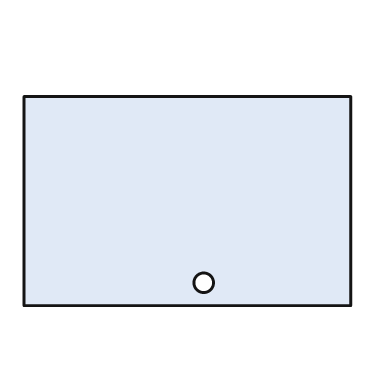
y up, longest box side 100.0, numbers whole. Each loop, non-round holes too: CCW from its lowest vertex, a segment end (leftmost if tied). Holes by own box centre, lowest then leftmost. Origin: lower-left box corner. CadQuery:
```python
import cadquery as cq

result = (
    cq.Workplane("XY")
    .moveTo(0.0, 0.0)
    .lineTo(100.0, 0.0)
    .lineTo(100.0, 64.0)
    .lineTo(0.0, 64.0)
    .close()
    .moveTo(55.0, 7.0)
    .circle(3.0)
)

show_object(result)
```